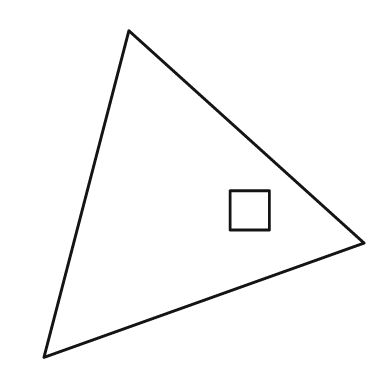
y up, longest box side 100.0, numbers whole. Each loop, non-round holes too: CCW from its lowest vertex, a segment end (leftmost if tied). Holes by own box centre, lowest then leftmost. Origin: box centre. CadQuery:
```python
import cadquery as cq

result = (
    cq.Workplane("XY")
    .moveTo(-49.0, -50.0)
    .lineTo(49.0, -15.0)
    .lineTo(-23.0, 50.0)
    .close()
    .moveTo(8.0, -11.0)
    .lineTo(20.0, -11.0)
    .lineTo(20.0, 1.0)
    .lineTo(8.0, 1.0)
    .close()
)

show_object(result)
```